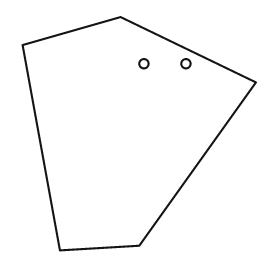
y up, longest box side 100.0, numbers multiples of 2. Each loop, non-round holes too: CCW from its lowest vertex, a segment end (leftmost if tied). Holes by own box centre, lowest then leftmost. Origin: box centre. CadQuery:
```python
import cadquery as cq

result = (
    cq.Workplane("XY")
    .moveTo(-34.0, -50.0)
    .lineTo(0.0, -48.0)
    .lineTo(50.0, 22.0)
    .lineTo(-8.0, 50.0)
    .lineTo(-50.0, 38.0)
    .close()
    .moveTo(2.0, 30.0)
    .circle(2.0)
    .moveTo(20.0, 30.0)
    .circle(2.0)
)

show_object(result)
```